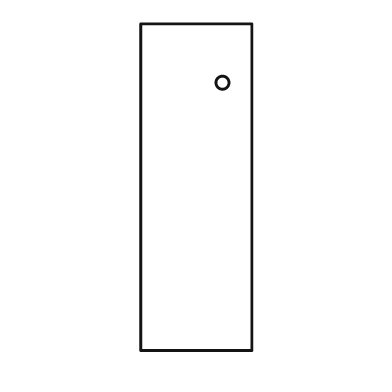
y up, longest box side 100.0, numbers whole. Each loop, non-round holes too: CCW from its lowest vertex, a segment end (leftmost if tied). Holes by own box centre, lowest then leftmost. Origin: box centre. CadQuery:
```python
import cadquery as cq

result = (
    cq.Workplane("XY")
    .moveTo(-17.0, -50.0)
    .lineTo(17.0, -50.0)
    .lineTo(17.0, 50.0)
    .lineTo(-17.0, 50.0)
    .close()
    .moveTo(8.0, 32.0)
    .circle(2.0)
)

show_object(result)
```